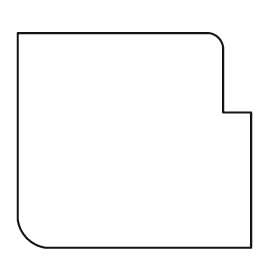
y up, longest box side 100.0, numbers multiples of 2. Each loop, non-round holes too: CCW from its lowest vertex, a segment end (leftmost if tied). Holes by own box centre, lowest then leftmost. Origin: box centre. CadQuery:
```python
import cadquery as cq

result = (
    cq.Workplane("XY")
    .moveTo(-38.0, -46.0)
    .lineTo(50.0, -46.0)
    .lineTo(50.0, 12.0)
    .lineTo(38.0, 12.0)
    .lineTo(38.0, 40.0)
    .threePointArc((36.0, 44.0), (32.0, 46.0))
    .lineTo(-50.0, 46.0)
    .lineTo(-50.0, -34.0)
    .threePointArc((-46.0, -42.0), (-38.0, -46.0))
    .close()
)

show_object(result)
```